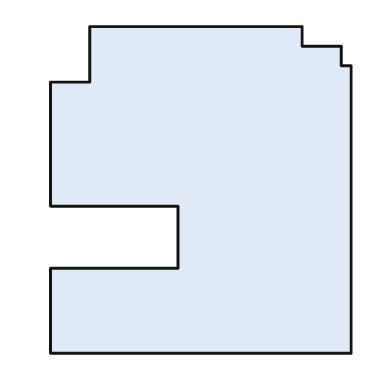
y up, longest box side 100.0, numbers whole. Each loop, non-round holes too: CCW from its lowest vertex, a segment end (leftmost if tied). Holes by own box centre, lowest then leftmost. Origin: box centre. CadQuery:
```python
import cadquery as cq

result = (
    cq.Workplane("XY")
    .moveTo(-46.0, -50.0)
    .lineTo(46.0, -50.0)
    .lineTo(46.0, 38.0)
    .lineTo(43.0, 38.0)
    .lineTo(43.0, 44.0)
    .lineTo(31.0, 44.0)
    .lineTo(31.0, 50.0)
    .lineTo(-34.0, 50.0)
    .lineTo(-34.0, 33.0)
    .lineTo(-46.0, 33.0)
    .lineTo(-46.0, -5.0)
    .lineTo(-7.0, -5.0)
    .lineTo(-7.0, -24.0)
    .lineTo(-46.0, -24.0)
    .close()
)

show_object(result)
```